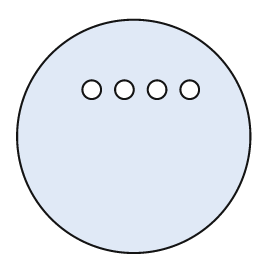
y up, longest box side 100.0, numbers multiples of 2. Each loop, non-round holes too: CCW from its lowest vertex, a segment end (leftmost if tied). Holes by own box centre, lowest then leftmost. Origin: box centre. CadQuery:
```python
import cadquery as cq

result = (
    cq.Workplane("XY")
    .moveTo(0.0, 0.0)
    .circle(50.0)
    .moveTo(-18.0, 20.0)
    .circle(4.0)
    .moveTo(-4.0, 20.0)
    .circle(4.0)
    .moveTo(10.0, 20.0)
    .circle(4.0)
    .moveTo(24.0, 20.0)
    .circle(4.0)
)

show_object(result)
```